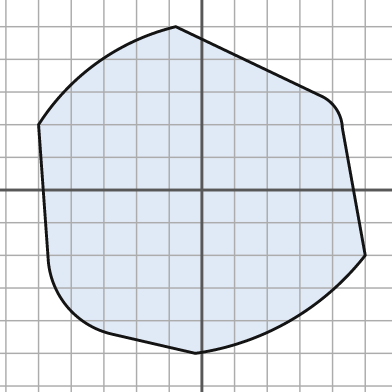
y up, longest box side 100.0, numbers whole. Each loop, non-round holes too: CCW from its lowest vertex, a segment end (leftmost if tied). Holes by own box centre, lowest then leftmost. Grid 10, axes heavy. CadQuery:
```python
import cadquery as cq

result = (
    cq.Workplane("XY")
    .moveTo(-2.0, -50.0)
    .threePointArc((27.0, -40.0), (50.0, -20.0))
    .lineTo(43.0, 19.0)
    .threePointArc((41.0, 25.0), (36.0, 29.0))
    .lineTo(-8.0, 50.0)
    .threePointArc((-32.0, 39.0), (-50.0, 20.0))
    .lineTo(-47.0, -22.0)
    .threePointArc((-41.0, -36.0), (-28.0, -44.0))
    .close()
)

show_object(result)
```